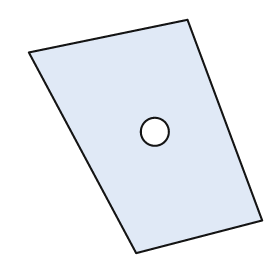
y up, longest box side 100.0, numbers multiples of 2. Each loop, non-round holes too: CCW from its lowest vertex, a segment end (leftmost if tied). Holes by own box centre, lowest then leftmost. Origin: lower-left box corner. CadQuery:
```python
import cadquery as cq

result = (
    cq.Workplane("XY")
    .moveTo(46.0, 0.0)
    .lineTo(100.0, 14.0)
    .lineTo(68.0, 100.0)
    .lineTo(0.0, 86.0)
    .close()
    .moveTo(54.0, 52.0)
    .circle(6.0)
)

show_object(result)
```